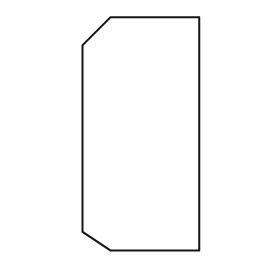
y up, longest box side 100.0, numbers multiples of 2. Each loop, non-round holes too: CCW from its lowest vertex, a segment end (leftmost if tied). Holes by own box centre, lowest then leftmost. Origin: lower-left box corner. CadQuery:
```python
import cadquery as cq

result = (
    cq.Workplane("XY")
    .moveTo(12.0, 0.0)
    .lineTo(50.0, 0.0)
    .lineTo(50.0, 100.0)
    .lineTo(12.0, 100.0)
    .lineTo(0.0, 88.0)
    .lineTo(0.0, 8.0)
    .close()
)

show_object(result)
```